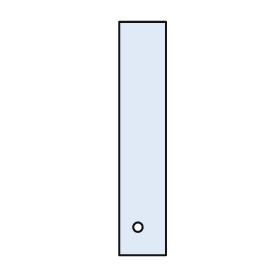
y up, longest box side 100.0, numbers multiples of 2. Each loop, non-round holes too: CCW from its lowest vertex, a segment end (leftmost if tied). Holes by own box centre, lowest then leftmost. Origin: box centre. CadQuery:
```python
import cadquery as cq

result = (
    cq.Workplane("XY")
    .moveTo(-10.0, -50.0)
    .lineTo(10.0, -50.0)
    .lineTo(10.0, 50.0)
    .lineTo(-10.0, 50.0)
    .close()
    .moveTo(-2.0, -38.0)
    .circle(2.0)
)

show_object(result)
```